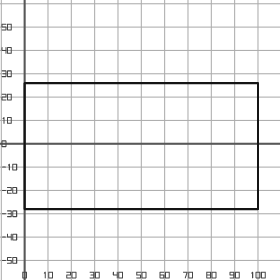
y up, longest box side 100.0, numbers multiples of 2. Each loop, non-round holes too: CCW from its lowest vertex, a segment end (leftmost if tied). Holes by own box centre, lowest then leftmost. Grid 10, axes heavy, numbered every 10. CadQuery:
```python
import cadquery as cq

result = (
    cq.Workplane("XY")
    .moveTo(0.0, -28.0)
    .lineTo(100.0, -28.0)
    .lineTo(100.0, 26.0)
    .lineTo(0.0, 26.0)
    .close()
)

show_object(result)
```